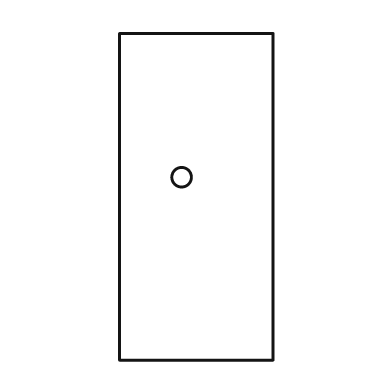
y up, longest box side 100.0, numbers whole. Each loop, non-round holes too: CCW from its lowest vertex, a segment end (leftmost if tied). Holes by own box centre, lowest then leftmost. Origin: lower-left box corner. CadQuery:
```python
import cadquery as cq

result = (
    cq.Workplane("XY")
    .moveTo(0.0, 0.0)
    .lineTo(47.0, 0.0)
    .lineTo(47.0, 100.0)
    .lineTo(0.0, 100.0)
    .close()
    .moveTo(19.0, 56.0)
    .circle(3.0)
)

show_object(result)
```